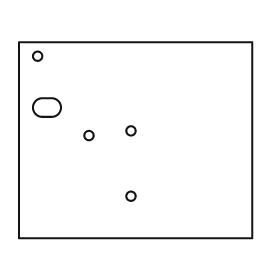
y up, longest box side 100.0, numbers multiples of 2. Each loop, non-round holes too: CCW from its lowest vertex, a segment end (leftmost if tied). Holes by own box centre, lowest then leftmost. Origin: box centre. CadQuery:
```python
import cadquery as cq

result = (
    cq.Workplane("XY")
    .moveTo(-50.0, -42.0)
    .lineTo(50.0, -42.0)
    .lineTo(50.0, 42.0)
    .lineTo(-50.0, 42.0)
    .close()
    .moveTo(-2.0, -24.0)
    .circle(2.0)
    .moveTo(-20.0, 2.0)
    .circle(2.0)
    .moveTo(-2.0, 4.0)
    .circle(2.0)
    .moveTo(-40.0, 10.0)
    .lineTo(-36.0, 10.0)
    .threePointArc((-32.0, 14.0), (-36.0, 18.0))
    .lineTo(-40.0, 18.0)
    .threePointArc((-44.0, 14.0), (-40.0, 10.0))
    .close()
    .moveTo(-42.0, 36.0)
    .circle(2.0)
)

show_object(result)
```